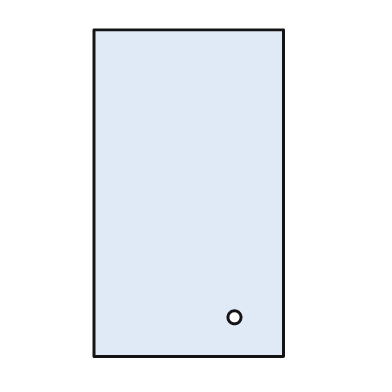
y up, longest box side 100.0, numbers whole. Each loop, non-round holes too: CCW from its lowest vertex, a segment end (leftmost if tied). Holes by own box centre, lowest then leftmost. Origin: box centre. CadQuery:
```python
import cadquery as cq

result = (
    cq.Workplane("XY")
    .moveTo(-29.0, -50.0)
    .lineTo(29.0, -50.0)
    .lineTo(29.0, 50.0)
    .lineTo(-29.0, 50.0)
    .close()
    .moveTo(14.0, -38.0)
    .circle(2.0)
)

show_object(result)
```